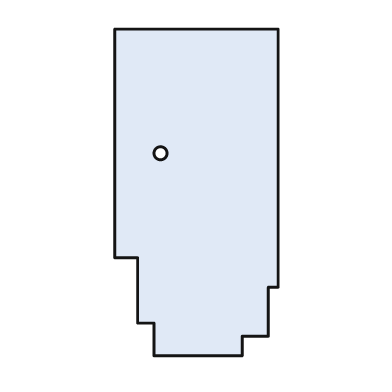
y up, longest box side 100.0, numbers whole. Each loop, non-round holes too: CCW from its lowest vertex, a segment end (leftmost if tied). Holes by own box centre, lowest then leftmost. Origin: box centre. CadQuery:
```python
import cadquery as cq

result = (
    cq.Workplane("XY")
    .moveTo(-13.0, -50.0)
    .lineTo(14.0, -50.0)
    .lineTo(14.0, -44.0)
    .lineTo(22.0, -44.0)
    .lineTo(22.0, -29.0)
    .lineTo(25.0, -29.0)
    .lineTo(25.0, 50.0)
    .lineTo(-25.0, 50.0)
    .lineTo(-25.0, -20.0)
    .lineTo(-18.0, -20.0)
    .lineTo(-18.0, -40.0)
    .lineTo(-13.0, -40.0)
    .close()
    .moveTo(-11.0, 12.0)
    .circle(2.0)
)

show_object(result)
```